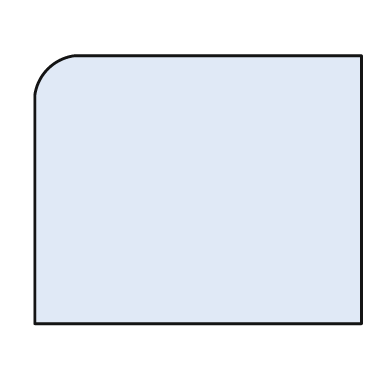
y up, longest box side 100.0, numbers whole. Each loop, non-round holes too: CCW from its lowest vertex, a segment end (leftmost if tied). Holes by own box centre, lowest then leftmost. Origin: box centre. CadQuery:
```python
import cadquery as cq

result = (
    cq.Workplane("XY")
    .moveTo(-50.0, -41.0)
    .lineTo(50.0, -41.0)
    .lineTo(50.0, 41.0)
    .lineTo(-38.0, 41.0)
    .threePointArc((-46.0, 37.0), (-50.0, 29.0))
    .close()
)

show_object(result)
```